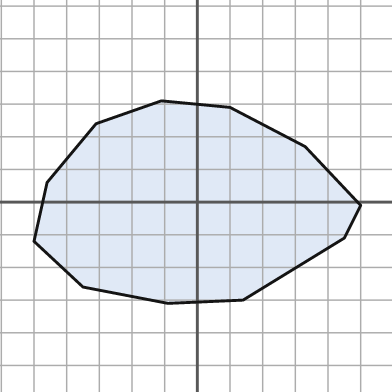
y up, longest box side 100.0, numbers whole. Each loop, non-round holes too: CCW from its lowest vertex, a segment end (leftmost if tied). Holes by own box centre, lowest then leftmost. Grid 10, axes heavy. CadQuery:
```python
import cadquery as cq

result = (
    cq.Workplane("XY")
    .moveTo(-9.0, -31.0)
    .lineTo(14.0, -30.0)
    .lineTo(45.0, -11.0)
    .lineTo(50.0, -1.0)
    .lineTo(33.0, 17.0)
    .lineTo(10.0, 29.0)
    .lineTo(-11.0, 31.0)
    .lineTo(-31.0, 24.0)
    .lineTo(-46.0, 6.0)
    .lineTo(-50.0, -12.0)
    .lineTo(-35.0, -26.0)
    .close()
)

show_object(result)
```